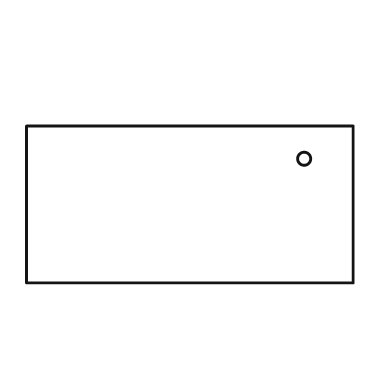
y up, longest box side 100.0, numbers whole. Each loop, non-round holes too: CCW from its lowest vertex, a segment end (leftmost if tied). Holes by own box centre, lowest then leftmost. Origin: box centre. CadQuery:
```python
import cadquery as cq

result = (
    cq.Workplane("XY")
    .moveTo(-50.0, -24.0)
    .lineTo(50.0, -24.0)
    .lineTo(50.0, 24.0)
    .lineTo(-50.0, 24.0)
    .close()
    .moveTo(35.0, 14.0)
    .circle(2.0)
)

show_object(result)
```